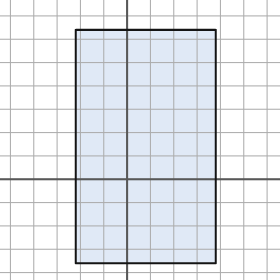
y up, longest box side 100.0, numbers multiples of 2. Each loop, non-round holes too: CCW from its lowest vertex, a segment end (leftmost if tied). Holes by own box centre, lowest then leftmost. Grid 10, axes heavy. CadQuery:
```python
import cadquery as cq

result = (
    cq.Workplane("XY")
    .moveTo(-22.0, -36.0)
    .lineTo(38.0, -36.0)
    .lineTo(38.0, 64.0)
    .lineTo(-22.0, 64.0)
    .close()
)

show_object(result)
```